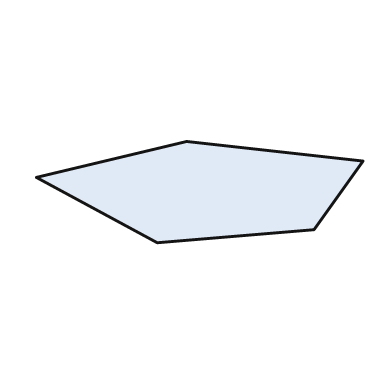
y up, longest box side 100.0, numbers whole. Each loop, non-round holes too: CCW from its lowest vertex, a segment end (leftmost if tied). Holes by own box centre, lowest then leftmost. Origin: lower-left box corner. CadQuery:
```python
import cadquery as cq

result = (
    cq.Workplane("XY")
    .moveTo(37.0, 0.0)
    .lineTo(85.0, 4.0)
    .lineTo(100.0, 25.0)
    .lineTo(46.0, 31.0)
    .lineTo(0.0, 20.0)
    .close()
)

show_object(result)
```